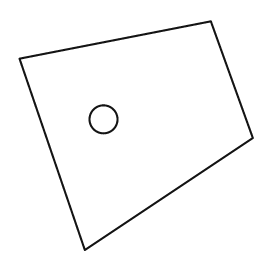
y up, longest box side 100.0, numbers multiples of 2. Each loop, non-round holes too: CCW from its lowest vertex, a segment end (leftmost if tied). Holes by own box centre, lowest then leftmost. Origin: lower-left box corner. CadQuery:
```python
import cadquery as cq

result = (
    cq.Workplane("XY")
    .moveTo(28.0, 0.0)
    .lineTo(100.0, 48.0)
    .lineTo(82.0, 98.0)
    .lineTo(0.0, 82.0)
    .close()
    .moveTo(36.0, 56.0)
    .circle(6.0)
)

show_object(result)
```